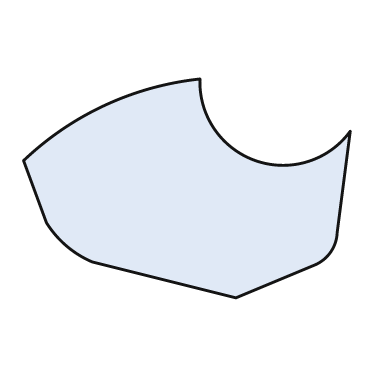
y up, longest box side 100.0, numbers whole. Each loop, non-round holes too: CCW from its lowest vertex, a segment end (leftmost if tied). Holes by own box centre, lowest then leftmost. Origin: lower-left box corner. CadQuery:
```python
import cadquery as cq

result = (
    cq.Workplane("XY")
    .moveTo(65.0, 0.0)
    .lineTo(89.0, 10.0)
    .threePointArc((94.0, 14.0), (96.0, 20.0))
    .lineTo(100.0, 51.0)
    .threePointArc((71.0, 42.0), (54.0, 67.0))
    .threePointArc((25.0, 59.0), (0.0, 42.0))
    .lineTo(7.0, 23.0)
    .threePointArc((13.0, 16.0), (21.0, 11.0))
    .close()
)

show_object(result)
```